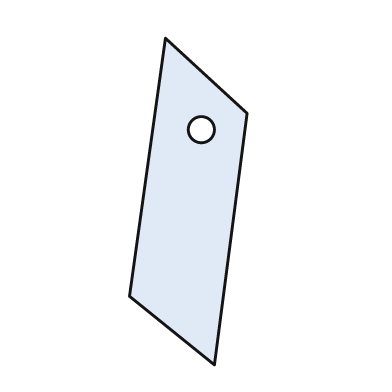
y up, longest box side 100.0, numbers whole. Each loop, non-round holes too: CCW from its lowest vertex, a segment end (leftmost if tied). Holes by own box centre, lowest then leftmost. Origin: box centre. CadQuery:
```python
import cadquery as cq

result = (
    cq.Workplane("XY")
    .moveTo(8.0, -50.0)
    .lineTo(18.0, 27.0)
    .lineTo(-7.0, 50.0)
    .lineTo(-18.0, -29.0)
    .close()
    .moveTo(4.0, 22.0)
    .circle(4.0)
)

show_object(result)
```